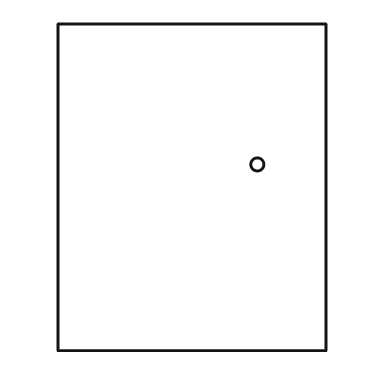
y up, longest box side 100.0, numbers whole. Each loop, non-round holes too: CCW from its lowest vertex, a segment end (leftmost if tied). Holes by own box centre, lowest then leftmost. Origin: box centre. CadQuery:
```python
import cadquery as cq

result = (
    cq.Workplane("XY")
    .moveTo(-41.0, -50.0)
    .lineTo(41.0, -50.0)
    .lineTo(41.0, 50.0)
    .lineTo(-41.0, 50.0)
    .close()
    .moveTo(20.0, 7.0)
    .circle(2.0)
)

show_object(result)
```